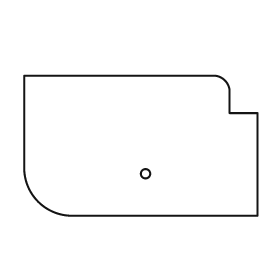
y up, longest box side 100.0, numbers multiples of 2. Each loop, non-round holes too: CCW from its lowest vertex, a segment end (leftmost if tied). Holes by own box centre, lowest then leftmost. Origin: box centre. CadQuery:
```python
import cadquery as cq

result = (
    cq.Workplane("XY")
    .moveTo(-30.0, -30.0)
    .lineTo(50.0, -30.0)
    .lineTo(50.0, 14.0)
    .lineTo(38.0, 14.0)
    .lineTo(38.0, 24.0)
    .threePointArc((36.0, 28.0), (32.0, 30.0))
    .lineTo(-50.0, 30.0)
    .lineTo(-50.0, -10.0)
    .threePointArc((-44.0, -24.0), (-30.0, -30.0))
    .close()
    .moveTo(2.0, -12.0)
    .circle(2.0)
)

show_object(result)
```